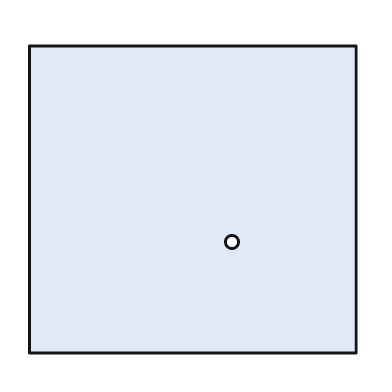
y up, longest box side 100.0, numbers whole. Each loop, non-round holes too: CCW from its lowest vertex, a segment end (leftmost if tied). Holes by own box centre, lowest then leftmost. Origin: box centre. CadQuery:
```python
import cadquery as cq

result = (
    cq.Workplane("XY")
    .moveTo(-50.0, -47.0)
    .lineTo(50.0, -47.0)
    .lineTo(50.0, 47.0)
    .lineTo(-50.0, 47.0)
    .close()
    .moveTo(12.0, -13.0)
    .circle(2.0)
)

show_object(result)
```